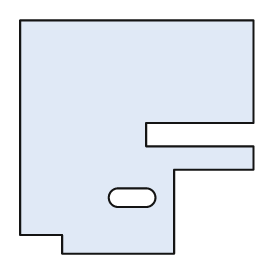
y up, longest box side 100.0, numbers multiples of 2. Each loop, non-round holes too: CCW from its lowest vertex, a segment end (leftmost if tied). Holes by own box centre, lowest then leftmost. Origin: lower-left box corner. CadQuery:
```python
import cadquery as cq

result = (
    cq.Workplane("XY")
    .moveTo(18.0, 0.0)
    .lineTo(66.0, 0.0)
    .lineTo(66.0, 36.0)
    .lineTo(100.0, 36.0)
    .lineTo(100.0, 46.0)
    .lineTo(54.0, 46.0)
    .lineTo(54.0, 56.0)
    .lineTo(100.0, 56.0)
    .lineTo(100.0, 100.0)
    .lineTo(0.0, 100.0)
    .lineTo(0.0, 8.0)
    .lineTo(18.0, 8.0)
    .close()
    .moveTo(42.0, 20.0)
    .lineTo(54.0, 20.0)
    .threePointArc((58.0, 24.0), (54.0, 28.0))
    .lineTo(42.0, 28.0)
    .threePointArc((38.0, 24.0), (42.0, 20.0))
    .close()
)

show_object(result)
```